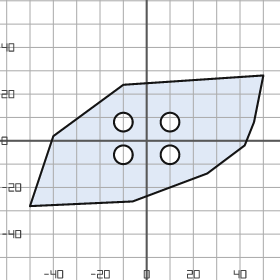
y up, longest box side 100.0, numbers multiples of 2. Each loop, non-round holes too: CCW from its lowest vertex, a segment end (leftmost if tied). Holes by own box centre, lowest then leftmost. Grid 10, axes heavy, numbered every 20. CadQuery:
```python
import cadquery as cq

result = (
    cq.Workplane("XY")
    .moveTo(-50.0, -28.0)
    .lineTo(-6.0, -26.0)
    .lineTo(26.0, -14.0)
    .lineTo(42.0, -2.0)
    .lineTo(46.0, 8.0)
    .lineTo(50.0, 28.0)
    .lineTo(-10.0, 24.0)
    .lineTo(-40.0, 2.0)
    .close()
    .moveTo(-10.0, -6.0)
    .circle(4.0)
    .moveTo(10.0, -6.0)
    .circle(4.0)
    .moveTo(-10.0, 8.0)
    .circle(4.0)
    .moveTo(10.0, 8.0)
    .circle(4.0)
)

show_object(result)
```